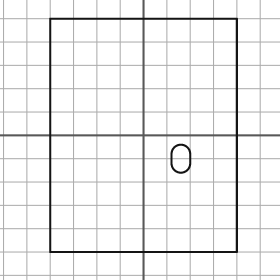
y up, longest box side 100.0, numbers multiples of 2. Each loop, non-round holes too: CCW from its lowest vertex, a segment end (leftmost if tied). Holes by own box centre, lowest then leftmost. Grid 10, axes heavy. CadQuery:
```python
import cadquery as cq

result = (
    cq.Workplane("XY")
    .moveTo(-40.0, -50.0)
    .lineTo(40.0, -50.0)
    .lineTo(40.0, 50.0)
    .lineTo(-40.0, 50.0)
    .close()
    .moveTo(12.0, -12.0)
    .threePointArc((16.0, -16.0), (20.0, -12.0))
    .lineTo(20.0, -8.0)
    .threePointArc((16.0, -4.0), (12.0, -8.0))
    .close()
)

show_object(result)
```